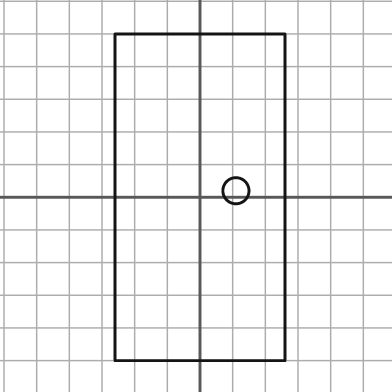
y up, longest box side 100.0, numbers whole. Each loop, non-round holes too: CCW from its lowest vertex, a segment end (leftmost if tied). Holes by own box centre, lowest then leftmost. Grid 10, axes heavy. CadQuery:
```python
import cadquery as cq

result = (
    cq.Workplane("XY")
    .moveTo(-26.0, -50.0)
    .lineTo(26.0, -50.0)
    .lineTo(26.0, 50.0)
    .lineTo(-26.0, 50.0)
    .close()
    .moveTo(11.0, 2.0)
    .circle(4.0)
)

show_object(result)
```